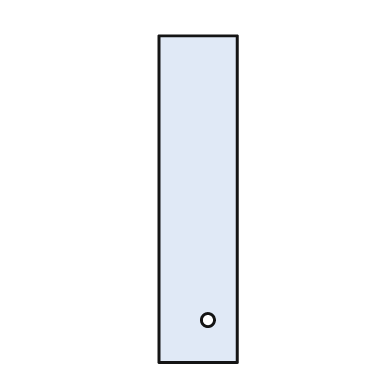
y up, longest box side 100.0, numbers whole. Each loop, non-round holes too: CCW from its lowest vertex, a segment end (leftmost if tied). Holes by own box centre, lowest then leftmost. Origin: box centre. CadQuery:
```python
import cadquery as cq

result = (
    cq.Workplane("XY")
    .moveTo(-12.0, -50.0)
    .lineTo(12.0, -50.0)
    .lineTo(12.0, 50.0)
    .lineTo(-12.0, 50.0)
    .close()
    .moveTo(3.0, -37.0)
    .circle(2.0)
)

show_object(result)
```